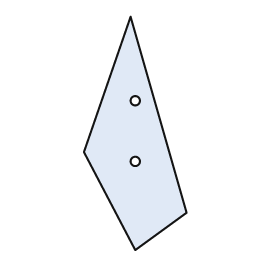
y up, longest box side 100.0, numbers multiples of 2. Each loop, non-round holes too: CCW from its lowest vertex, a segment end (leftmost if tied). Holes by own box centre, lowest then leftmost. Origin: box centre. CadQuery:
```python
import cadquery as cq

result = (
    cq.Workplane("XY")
    .moveTo(0.0, -50.0)
    .lineTo(22.0, -34.0)
    .lineTo(-2.0, 50.0)
    .lineTo(-22.0, -8.0)
    .close()
    .moveTo(0.0, -12.0)
    .circle(2.0)
    .moveTo(0.0, 14.0)
    .circle(2.0)
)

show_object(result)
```